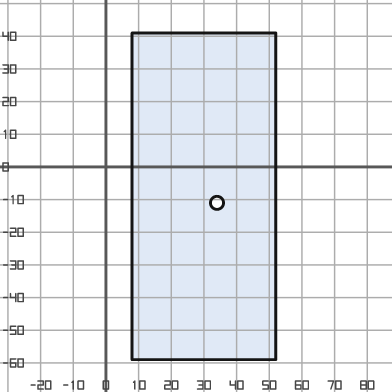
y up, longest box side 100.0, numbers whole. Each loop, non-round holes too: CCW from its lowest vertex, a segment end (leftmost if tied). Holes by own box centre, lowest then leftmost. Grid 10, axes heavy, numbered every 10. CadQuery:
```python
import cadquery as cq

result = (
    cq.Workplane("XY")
    .moveTo(8.0, -59.0)
    .lineTo(52.0, -59.0)
    .lineTo(52.0, 41.0)
    .lineTo(8.0, 41.0)
    .close()
    .moveTo(34.0, -11.0)
    .circle(2.0)
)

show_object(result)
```